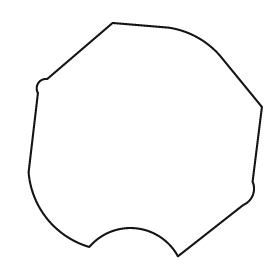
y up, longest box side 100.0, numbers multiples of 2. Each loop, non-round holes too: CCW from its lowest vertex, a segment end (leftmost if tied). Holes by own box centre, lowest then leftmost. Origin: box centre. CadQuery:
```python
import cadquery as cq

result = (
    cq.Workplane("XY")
    .moveTo(14.0, -50.0)
    .lineTo(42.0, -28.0)
    .threePointArc((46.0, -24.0), (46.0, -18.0))
    .lineTo(50.0, 14.0)
    .lineTo(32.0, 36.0)
    .threePointArc((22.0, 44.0), (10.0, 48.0))
    .lineTo(-14.0, 50.0)
    .lineTo(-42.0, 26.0)
    .threePointArc((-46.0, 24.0), (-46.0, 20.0))
    .lineTo(-50.0, -14.0)
    .threePointArc((-42.0, -34.0), (-24.0, -46.0))
    .threePointArc((-4.0, -38.0), (14.0, -50.0))
    .close()
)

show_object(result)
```